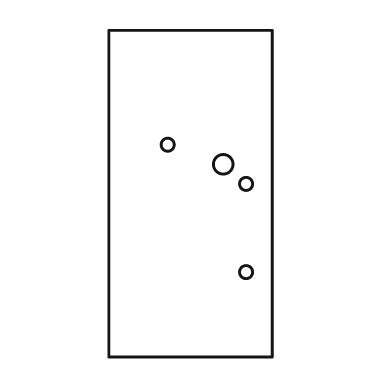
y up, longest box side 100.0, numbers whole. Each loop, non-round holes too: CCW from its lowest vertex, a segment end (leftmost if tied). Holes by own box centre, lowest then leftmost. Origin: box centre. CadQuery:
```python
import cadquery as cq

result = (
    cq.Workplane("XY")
    .moveTo(-25.0, -50.0)
    .lineTo(25.0, -50.0)
    .lineTo(25.0, 50.0)
    .lineTo(-25.0, 50.0)
    .close()
    .moveTo(17.0, -24.0)
    .circle(2.0)
    .moveTo(17.0, 3.0)
    .circle(2.0)
    .moveTo(10.0, 9.0)
    .circle(3.0)
    .moveTo(-7.0, 15.0)
    .circle(2.0)
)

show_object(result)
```